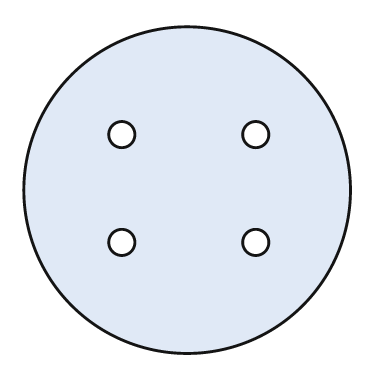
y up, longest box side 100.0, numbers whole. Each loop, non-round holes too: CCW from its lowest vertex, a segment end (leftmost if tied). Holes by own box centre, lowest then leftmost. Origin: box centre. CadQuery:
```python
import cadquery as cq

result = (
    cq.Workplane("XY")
    .moveTo(0.0, 0.0)
    .circle(50.0)
    .moveTo(-20.0, -16.0)
    .circle(4.0)
    .moveTo(21.0, -16.0)
    .circle(4.0)
    .moveTo(-20.0, 17.0)
    .circle(4.0)
    .moveTo(21.0, 17.0)
    .circle(4.0)
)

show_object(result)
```